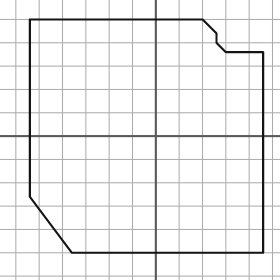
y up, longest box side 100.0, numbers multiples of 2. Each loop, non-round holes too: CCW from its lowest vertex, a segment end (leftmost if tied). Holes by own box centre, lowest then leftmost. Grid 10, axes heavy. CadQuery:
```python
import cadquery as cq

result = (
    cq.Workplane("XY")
    .moveTo(-36.0, -50.0)
    .lineTo(46.0, -50.0)
    .lineTo(46.0, 36.0)
    .lineTo(30.0, 36.0)
    .lineTo(26.0, 40.0)
    .lineTo(26.0, 44.0)
    .lineTo(20.0, 50.0)
    .lineTo(-54.0, 50.0)
    .lineTo(-54.0, -26.0)
    .close()
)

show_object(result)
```